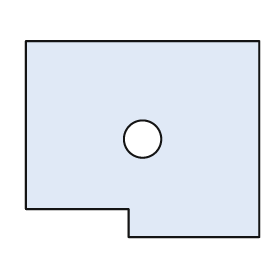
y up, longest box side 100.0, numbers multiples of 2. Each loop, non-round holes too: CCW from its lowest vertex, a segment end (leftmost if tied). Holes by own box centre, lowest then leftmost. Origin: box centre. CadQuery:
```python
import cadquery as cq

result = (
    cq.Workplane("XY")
    .moveTo(-6.0, -42.0)
    .lineTo(50.0, -42.0)
    .lineTo(50.0, 42.0)
    .lineTo(-50.0, 42.0)
    .lineTo(-50.0, -30.0)
    .lineTo(-6.0, -30.0)
    .close()
    .moveTo(0.0, 0.0)
    .circle(8.0)
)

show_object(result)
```